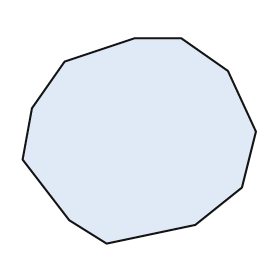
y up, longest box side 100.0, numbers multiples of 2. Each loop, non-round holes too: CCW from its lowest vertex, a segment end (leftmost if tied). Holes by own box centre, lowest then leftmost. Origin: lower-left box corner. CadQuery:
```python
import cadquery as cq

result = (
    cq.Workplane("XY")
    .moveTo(36.0, 0.0)
    .lineTo(74.0, 8.0)
    .lineTo(94.0, 24.0)
    .lineTo(100.0, 48.0)
    .lineTo(88.0, 74.0)
    .lineTo(68.0, 88.0)
    .lineTo(48.0, 88.0)
    .lineTo(18.0, 78.0)
    .lineTo(4.0, 58.0)
    .lineTo(0.0, 36.0)
    .lineTo(20.0, 10.0)
    .close()
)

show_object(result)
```